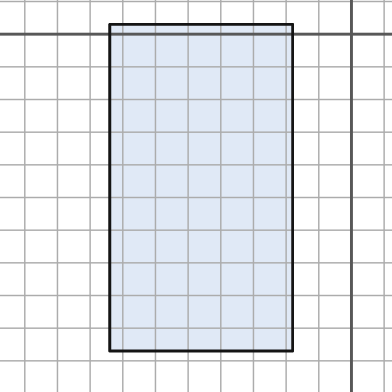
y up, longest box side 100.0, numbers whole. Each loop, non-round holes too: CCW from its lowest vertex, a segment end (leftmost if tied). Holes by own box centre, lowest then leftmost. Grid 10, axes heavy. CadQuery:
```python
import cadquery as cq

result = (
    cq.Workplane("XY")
    .moveTo(-74.0, -97.0)
    .lineTo(-18.0, -97.0)
    .lineTo(-18.0, 3.0)
    .lineTo(-74.0, 3.0)
    .close()
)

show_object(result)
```